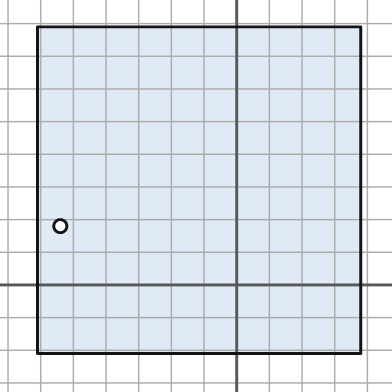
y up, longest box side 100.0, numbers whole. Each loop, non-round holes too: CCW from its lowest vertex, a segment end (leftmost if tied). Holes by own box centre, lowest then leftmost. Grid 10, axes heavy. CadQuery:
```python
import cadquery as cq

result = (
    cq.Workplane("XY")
    .moveTo(-61.0, -21.0)
    .lineTo(38.0, -21.0)
    .lineTo(38.0, 79.0)
    .lineTo(-61.0, 79.0)
    .close()
    .moveTo(-54.0, 18.0)
    .circle(2.0)
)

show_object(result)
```